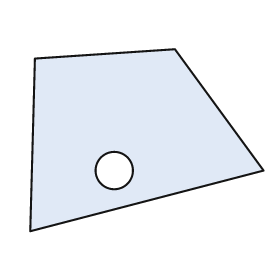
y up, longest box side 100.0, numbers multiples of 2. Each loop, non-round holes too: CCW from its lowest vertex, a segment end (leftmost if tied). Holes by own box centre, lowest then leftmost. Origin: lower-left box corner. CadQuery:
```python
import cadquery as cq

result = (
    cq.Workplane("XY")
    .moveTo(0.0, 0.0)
    .lineTo(100.0, 26.0)
    .lineTo(62.0, 78.0)
    .lineTo(2.0, 74.0)
    .close()
    .moveTo(36.0, 26.0)
    .circle(8.0)
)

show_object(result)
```